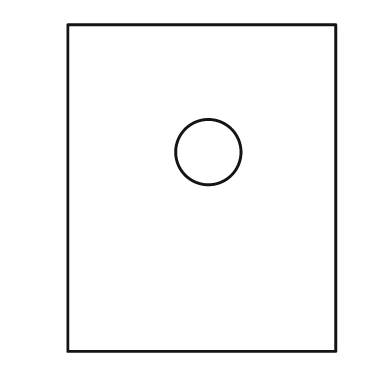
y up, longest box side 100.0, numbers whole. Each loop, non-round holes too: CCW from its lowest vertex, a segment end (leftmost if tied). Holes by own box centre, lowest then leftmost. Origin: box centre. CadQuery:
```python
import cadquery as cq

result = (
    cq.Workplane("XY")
    .moveTo(-41.0, -50.0)
    .lineTo(41.0, -50.0)
    .lineTo(41.0, 50.0)
    .lineTo(-41.0, 50.0)
    .close()
    .moveTo(2.0, 11.0)
    .circle(10.0)
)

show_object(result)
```